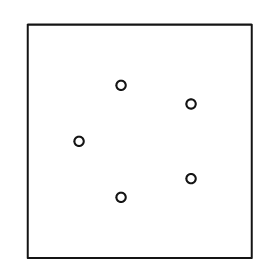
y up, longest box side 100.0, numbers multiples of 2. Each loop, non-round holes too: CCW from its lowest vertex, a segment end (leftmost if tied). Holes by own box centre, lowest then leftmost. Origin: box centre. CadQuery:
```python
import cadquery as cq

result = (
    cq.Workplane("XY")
    .moveTo(-48.0, -50.0)
    .lineTo(48.0, -50.0)
    .lineTo(48.0, 50.0)
    .lineTo(-48.0, 50.0)
    .close()
    .moveTo(-8.0, -24.0)
    .circle(2.0)
    .moveTo(22.0, -16.0)
    .circle(2.0)
    .moveTo(-26.0, 0.0)
    .circle(2.0)
    .moveTo(22.0, 16.0)
    .circle(2.0)
    .moveTo(-8.0, 24.0)
    .circle(2.0)
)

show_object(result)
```